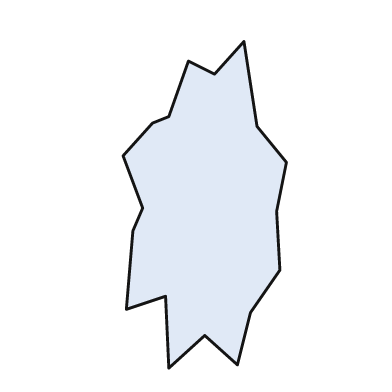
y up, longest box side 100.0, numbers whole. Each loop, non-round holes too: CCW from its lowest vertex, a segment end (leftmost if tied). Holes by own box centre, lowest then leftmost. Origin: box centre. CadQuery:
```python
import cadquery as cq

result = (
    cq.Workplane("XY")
    .moveTo(-11.0, -50.0)
    .lineTo(0.0, -40.0)
    .lineTo(10.0, -49.0)
    .lineTo(14.0, -33.0)
    .lineTo(23.0, -20.0)
    .lineTo(22.0, -2.0)
    .lineTo(25.0, 13.0)
    .lineTo(16.0, 24.0)
    .lineTo(12.0, 50.0)
    .lineTo(3.0, 40.0)
    .lineTo(-5.0, 44.0)
    .lineTo(-11.0, 27.0)
    .lineTo(-16.0, 25.0)
    .lineTo(-25.0, 15.0)
    .lineTo(-19.0, -1.0)
    .lineTo(-22.0, -8.0)
    .lineTo(-24.0, -32.0)
    .lineTo(-12.0, -28.0)
    .close()
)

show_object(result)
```